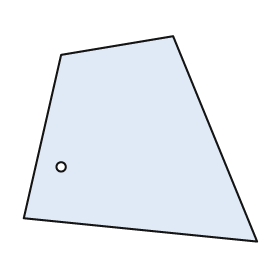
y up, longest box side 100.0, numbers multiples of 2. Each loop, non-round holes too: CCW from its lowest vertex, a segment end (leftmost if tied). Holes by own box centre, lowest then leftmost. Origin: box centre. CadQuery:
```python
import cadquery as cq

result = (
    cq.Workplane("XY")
    .moveTo(50.0, -44.0)
    .lineTo(14.0, 44.0)
    .lineTo(-34.0, 36.0)
    .lineTo(-50.0, -34.0)
    .close()
    .moveTo(-34.0, -12.0)
    .circle(2.0)
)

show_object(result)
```